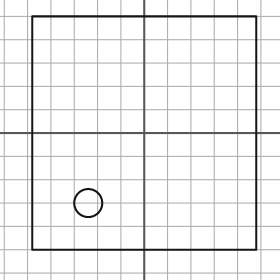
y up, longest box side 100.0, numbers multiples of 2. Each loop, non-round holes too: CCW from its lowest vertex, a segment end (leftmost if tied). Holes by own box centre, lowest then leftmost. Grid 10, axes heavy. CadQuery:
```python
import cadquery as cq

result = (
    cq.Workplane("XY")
    .moveTo(-48.0, -50.0)
    .lineTo(48.0, -50.0)
    .lineTo(48.0, 50.0)
    .lineTo(-48.0, 50.0)
    .close()
    .moveTo(-24.0, -30.0)
    .circle(6.0)
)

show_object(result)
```